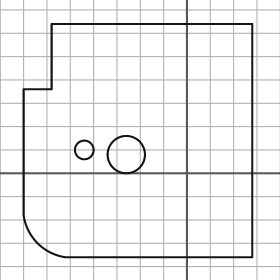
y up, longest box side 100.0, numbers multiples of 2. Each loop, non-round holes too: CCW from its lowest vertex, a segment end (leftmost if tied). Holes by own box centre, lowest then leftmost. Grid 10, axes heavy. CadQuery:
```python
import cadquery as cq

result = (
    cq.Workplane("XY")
    .moveTo(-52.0, -36.0)
    .lineTo(28.0, -36.0)
    .lineTo(28.0, 64.0)
    .lineTo(-58.0, 64.0)
    .lineTo(-58.0, 36.0)
    .lineTo(-70.0, 36.0)
    .lineTo(-70.0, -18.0)
    .threePointArc((-64.0, -30.0), (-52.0, -36.0))
    .close()
    .moveTo(-26.0, 8.0)
    .circle(8.0)
    .moveTo(-44.0, 10.0)
    .circle(4.0)
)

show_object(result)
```